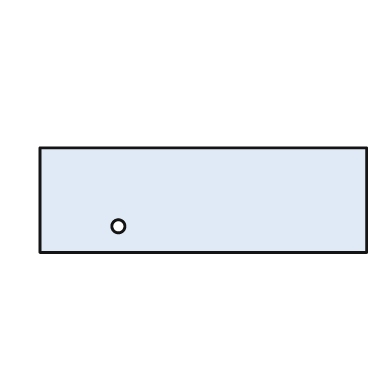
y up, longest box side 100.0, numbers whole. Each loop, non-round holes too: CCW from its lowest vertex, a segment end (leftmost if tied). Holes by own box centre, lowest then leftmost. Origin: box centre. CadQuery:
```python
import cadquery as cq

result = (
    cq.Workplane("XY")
    .moveTo(-50.0, -16.0)
    .lineTo(50.0, -16.0)
    .lineTo(50.0, 16.0)
    .lineTo(-50.0, 16.0)
    .close()
    .moveTo(-26.0, -8.0)
    .circle(2.0)
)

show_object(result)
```